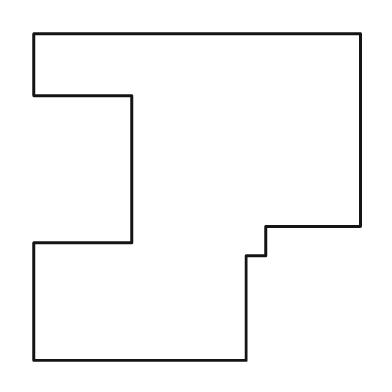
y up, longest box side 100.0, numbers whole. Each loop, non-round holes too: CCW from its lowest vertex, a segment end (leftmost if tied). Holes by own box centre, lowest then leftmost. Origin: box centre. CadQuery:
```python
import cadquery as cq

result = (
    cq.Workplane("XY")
    .moveTo(-50.0, -50.0)
    .lineTo(15.0, -50.0)
    .lineTo(15.0, -18.0)
    .lineTo(21.0, -18.0)
    .lineTo(21.0, -9.0)
    .lineTo(50.0, -9.0)
    .lineTo(50.0, 50.0)
    .lineTo(-50.0, 50.0)
    .lineTo(-50.0, 31.0)
    .lineTo(-20.0, 31.0)
    .lineTo(-20.0, -14.0)
    .lineTo(-50.0, -14.0)
    .close()
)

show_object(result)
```